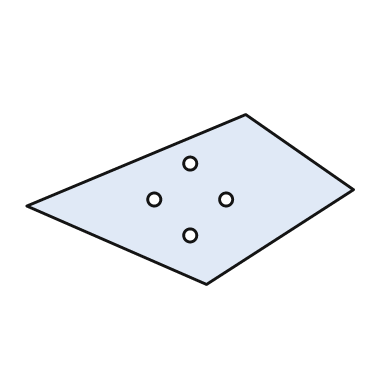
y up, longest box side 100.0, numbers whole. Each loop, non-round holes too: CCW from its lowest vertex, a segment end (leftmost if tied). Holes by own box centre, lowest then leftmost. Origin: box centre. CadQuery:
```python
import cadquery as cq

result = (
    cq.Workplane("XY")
    .moveTo(5.0, -26.0)
    .lineTo(50.0, 3.0)
    .lineTo(17.0, 26.0)
    .lineTo(-50.0, -2.0)
    .close()
    .moveTo(0.0, -11.0)
    .circle(2.0)
    .moveTo(-11.0, 0.0)
    .circle(2.0)
    .moveTo(11.0, 0.0)
    .circle(2.0)
    .moveTo(0.0, 11.0)
    .circle(2.0)
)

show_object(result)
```